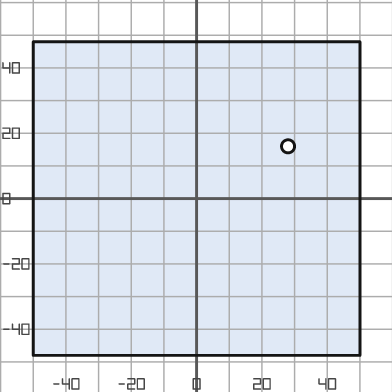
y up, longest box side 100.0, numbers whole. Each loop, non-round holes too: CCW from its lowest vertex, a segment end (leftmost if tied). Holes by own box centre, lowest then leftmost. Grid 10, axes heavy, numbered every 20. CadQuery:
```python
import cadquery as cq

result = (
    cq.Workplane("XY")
    .moveTo(-50.0, -48.0)
    .lineTo(50.0, -48.0)
    .lineTo(50.0, 48.0)
    .lineTo(-50.0, 48.0)
    .close()
    .moveTo(28.0, 16.0)
    .circle(2.0)
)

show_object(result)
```